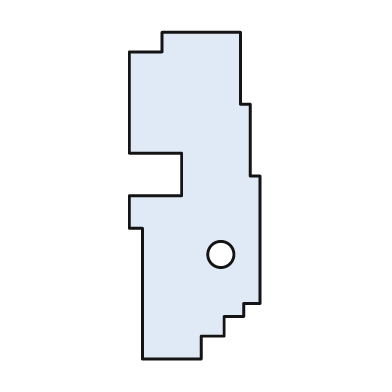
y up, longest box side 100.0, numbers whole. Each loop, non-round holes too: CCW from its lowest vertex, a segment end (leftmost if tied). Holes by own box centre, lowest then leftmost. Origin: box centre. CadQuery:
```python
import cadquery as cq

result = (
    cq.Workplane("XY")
    .moveTo(-16.0, -50.0)
    .lineTo(2.0, -50.0)
    .lineTo(2.0, -43.0)
    .lineTo(9.0, -43.0)
    .lineTo(9.0, -37.0)
    .lineTo(15.0, -37.0)
    .lineTo(15.0, -33.0)
    .lineTo(20.0, -33.0)
    .lineTo(20.0, 6.0)
    .lineTo(17.0, 6.0)
    .lineTo(17.0, 28.0)
    .lineTo(14.0, 28.0)
    .lineTo(14.0, 50.0)
    .lineTo(-10.0, 50.0)
    .lineTo(-10.0, 44.0)
    .lineTo(-20.0, 44.0)
    .lineTo(-20.0, 13.0)
    .lineTo(-4.0, 13.0)
    .lineTo(-4.0, 0.0)
    .lineTo(-20.0, 0.0)
    .lineTo(-20.0, -10.0)
    .lineTo(-16.0, -10.0)
    .close()
    .moveTo(8.0, -18.0)
    .circle(4.0)
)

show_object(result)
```